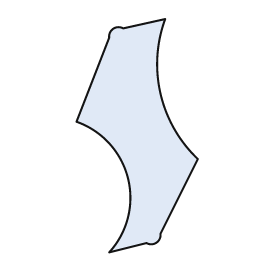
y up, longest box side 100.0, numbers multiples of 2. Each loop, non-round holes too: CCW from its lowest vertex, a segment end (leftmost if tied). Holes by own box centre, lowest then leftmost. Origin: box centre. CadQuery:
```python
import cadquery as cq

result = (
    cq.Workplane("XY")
    .moveTo(-12.0, -50.0)
    .lineTo(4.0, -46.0)
    .threePointArc((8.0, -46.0), (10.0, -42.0))
    .lineTo(26.0, -10.0)
    .threePointArc((10.0, 18.0), (12.0, 50.0))
    .lineTo(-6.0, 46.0)
    .threePointArc((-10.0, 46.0), (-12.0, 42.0))
    .lineTo(-26.0, 6.0)
    .threePointArc((-4.0, -18.0), (-12.0, -50.0))
    .close()
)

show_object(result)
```